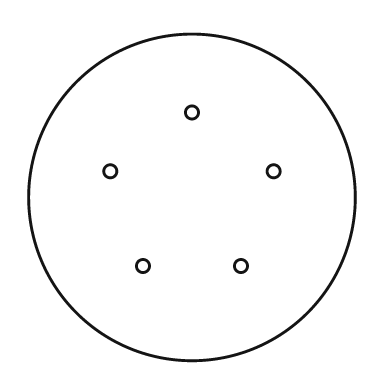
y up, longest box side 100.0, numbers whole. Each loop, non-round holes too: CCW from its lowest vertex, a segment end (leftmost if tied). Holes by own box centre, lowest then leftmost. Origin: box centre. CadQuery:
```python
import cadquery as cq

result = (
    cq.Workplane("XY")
    .moveTo(0.0, 0.0)
    .circle(50.0)
    .moveTo(-15.0, -21.0)
    .circle(2.0)
    .moveTo(15.0, -21.0)
    .circle(2.0)
    .moveTo(-25.0, 8.0)
    .circle(2.0)
    .moveTo(25.0, 8.0)
    .circle(2.0)
    .moveTo(0.0, 26.0)
    .circle(2.0)
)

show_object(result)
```